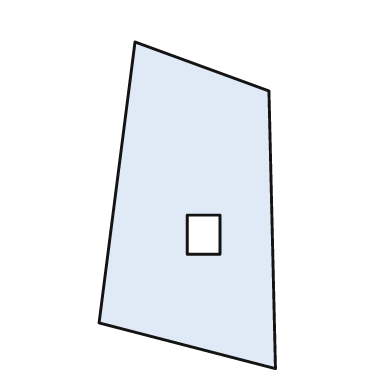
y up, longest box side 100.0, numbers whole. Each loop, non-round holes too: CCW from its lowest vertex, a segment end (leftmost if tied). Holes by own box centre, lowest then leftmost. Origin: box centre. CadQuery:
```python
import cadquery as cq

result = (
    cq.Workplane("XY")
    .moveTo(27.0, -50.0)
    .lineTo(25.0, 35.0)
    .lineTo(-16.0, 50.0)
    .lineTo(-27.0, -36.0)
    .close()
    .moveTo(0.0, -15.0)
    .lineTo(10.0, -15.0)
    .lineTo(10.0, -3.0)
    .lineTo(0.0, -3.0)
    .close()
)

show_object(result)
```